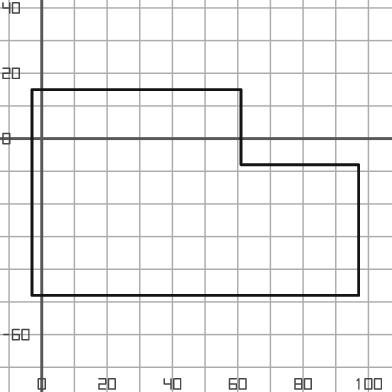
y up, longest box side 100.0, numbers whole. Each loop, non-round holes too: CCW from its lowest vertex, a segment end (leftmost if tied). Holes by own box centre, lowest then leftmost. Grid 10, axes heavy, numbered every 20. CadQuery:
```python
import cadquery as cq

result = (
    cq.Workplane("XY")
    .moveTo(-3.0, -48.0)
    .lineTo(97.0, -48.0)
    .lineTo(97.0, -8.0)
    .lineTo(61.0, -8.0)
    .lineTo(61.0, 15.0)
    .lineTo(-3.0, 15.0)
    .close()
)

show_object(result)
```